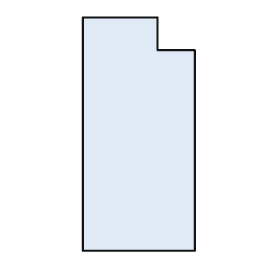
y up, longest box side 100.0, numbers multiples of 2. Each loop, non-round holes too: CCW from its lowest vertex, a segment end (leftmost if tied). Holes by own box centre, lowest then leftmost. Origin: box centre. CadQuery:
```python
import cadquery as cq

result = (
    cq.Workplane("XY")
    .moveTo(-24.0, -50.0)
    .lineTo(24.0, -50.0)
    .lineTo(24.0, 36.0)
    .lineTo(8.0, 36.0)
    .lineTo(8.0, 50.0)
    .lineTo(-24.0, 50.0)
    .close()
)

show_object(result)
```